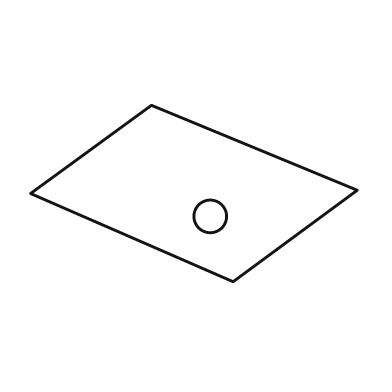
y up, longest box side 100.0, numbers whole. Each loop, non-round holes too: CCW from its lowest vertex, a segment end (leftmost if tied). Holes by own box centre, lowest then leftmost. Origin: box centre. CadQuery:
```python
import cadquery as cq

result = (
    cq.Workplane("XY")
    .moveTo(12.0, -27.0)
    .lineTo(50.0, 1.0)
    .lineTo(-13.0, 27.0)
    .lineTo(-50.0, 0.0)
    .close()
    .moveTo(5.0, -7.0)
    .circle(5.0)
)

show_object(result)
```